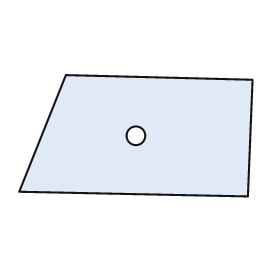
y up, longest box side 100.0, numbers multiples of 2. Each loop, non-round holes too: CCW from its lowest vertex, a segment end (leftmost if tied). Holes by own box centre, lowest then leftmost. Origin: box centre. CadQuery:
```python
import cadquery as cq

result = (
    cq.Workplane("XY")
    .moveTo(48.0, -26.0)
    .lineTo(50.0, 24.0)
    .lineTo(-30.0, 26.0)
    .lineTo(-50.0, -24.0)
    .close()
    .moveTo(0.0, 0.0)
    .circle(4.0)
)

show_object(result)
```